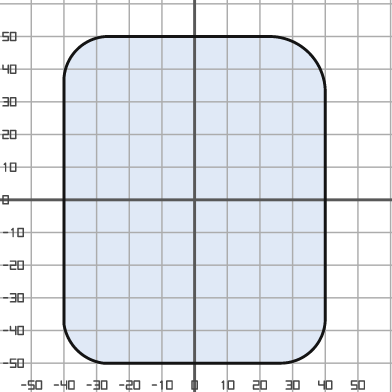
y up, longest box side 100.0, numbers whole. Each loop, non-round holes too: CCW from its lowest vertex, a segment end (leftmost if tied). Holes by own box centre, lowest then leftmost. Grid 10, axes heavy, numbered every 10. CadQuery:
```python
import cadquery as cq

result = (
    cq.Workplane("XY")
    .moveTo(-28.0, -50.0)
    .lineTo(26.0, -50.0)
    .threePointArc((36.0, -46.0), (40.0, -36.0))
    .lineTo(40.0, 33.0)
    .threePointArc((35.0, 45.0), (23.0, 50.0))
    .lineTo(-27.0, 50.0)
    .threePointArc((-36.0, 46.0), (-40.0, 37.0))
    .lineTo(-40.0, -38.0)
    .threePointArc((-36.0, -46.0), (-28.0, -50.0))
    .close()
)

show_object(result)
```